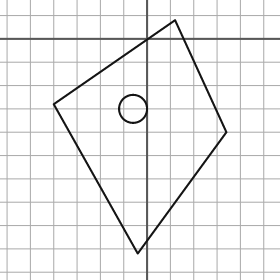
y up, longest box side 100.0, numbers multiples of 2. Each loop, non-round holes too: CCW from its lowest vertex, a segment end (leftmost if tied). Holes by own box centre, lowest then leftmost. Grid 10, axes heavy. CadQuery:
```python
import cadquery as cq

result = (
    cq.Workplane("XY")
    .moveTo(-4.0, -92.0)
    .lineTo(34.0, -40.0)
    .lineTo(12.0, 8.0)
    .lineTo(-40.0, -28.0)
    .close()
    .moveTo(-6.0, -30.0)
    .circle(6.0)
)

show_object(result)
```